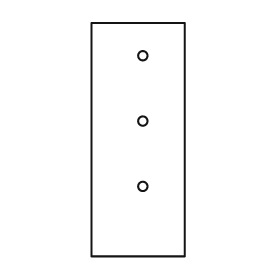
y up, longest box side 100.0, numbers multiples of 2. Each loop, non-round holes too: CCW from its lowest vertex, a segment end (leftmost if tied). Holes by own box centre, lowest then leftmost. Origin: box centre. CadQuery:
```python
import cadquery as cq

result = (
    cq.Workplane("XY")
    .moveTo(-20.0, -50.0)
    .lineTo(20.0, -50.0)
    .lineTo(20.0, 50.0)
    .lineTo(-20.0, 50.0)
    .close()
    .moveTo(2.0, -20.0)
    .circle(2.0)
    .moveTo(2.0, 8.0)
    .circle(2.0)
    .moveTo(2.0, 36.0)
    .circle(2.0)
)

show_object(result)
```